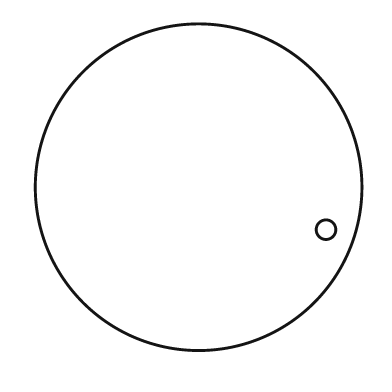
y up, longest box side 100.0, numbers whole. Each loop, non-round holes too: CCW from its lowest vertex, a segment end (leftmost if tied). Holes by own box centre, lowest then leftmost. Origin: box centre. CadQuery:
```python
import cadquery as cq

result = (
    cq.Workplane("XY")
    .moveTo(0.0, 0.0)
    .circle(50.0)
    .moveTo(39.0, -13.0)
    .circle(3.0)
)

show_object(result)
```